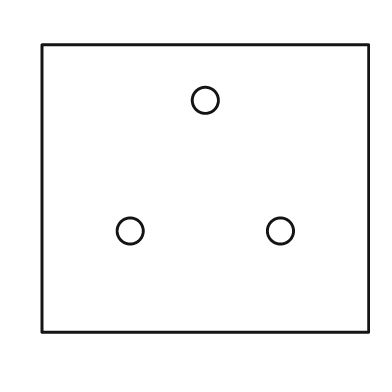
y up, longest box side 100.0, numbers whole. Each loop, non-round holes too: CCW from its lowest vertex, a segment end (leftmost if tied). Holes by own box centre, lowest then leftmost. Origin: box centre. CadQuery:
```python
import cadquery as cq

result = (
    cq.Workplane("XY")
    .moveTo(-50.0, -44.0)
    .lineTo(50.0, -44.0)
    .lineTo(50.0, 44.0)
    .lineTo(-50.0, 44.0)
    .close()
    .moveTo(-23.0, -13.0)
    .circle(4.0)
    .moveTo(23.0, -13.0)
    .circle(4.0)
    .moveTo(0.0, 27.0)
    .circle(4.0)
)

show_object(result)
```